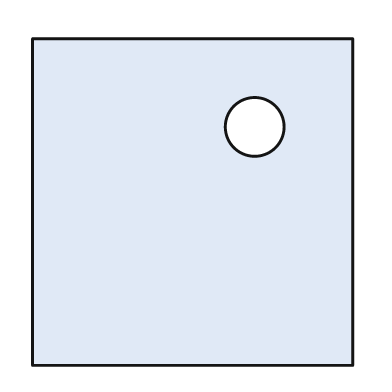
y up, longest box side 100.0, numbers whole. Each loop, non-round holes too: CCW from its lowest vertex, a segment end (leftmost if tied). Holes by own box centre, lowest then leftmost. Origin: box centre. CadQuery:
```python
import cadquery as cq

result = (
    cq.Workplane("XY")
    .moveTo(-49.0, -50.0)
    .lineTo(49.0, -50.0)
    .lineTo(49.0, 50.0)
    .lineTo(-49.0, 50.0)
    .close()
    .moveTo(19.0, 23.0)
    .circle(9.0)
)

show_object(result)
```